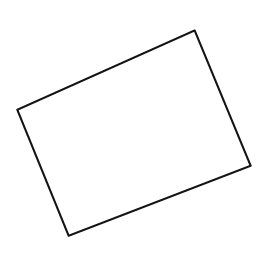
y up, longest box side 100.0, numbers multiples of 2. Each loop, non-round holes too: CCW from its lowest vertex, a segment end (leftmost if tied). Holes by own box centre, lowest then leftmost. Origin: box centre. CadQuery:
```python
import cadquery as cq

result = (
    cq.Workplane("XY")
    .moveTo(-28.0, -44.0)
    .lineTo(50.0, -14.0)
    .lineTo(26.0, 44.0)
    .lineTo(-50.0, 10.0)
    .close()
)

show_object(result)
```